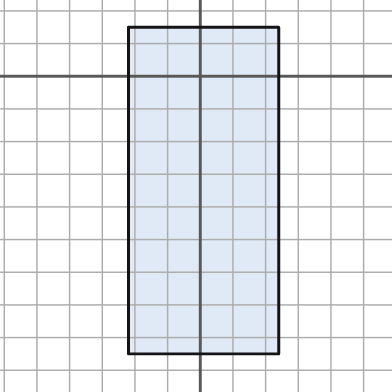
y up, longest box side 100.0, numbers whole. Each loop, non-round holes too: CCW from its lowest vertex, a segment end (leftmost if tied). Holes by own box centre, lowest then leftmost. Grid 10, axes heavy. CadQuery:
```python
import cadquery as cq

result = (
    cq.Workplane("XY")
    .moveTo(-22.0, -85.0)
    .lineTo(24.0, -85.0)
    .lineTo(24.0, 15.0)
    .lineTo(-22.0, 15.0)
    .close()
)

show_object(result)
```